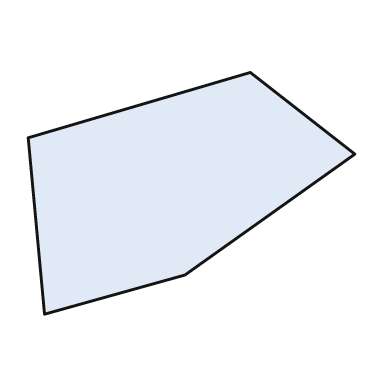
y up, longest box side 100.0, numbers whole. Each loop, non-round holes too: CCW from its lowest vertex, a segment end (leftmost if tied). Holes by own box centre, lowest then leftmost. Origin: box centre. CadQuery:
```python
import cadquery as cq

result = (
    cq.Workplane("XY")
    .moveTo(-45.0, -37.0)
    .lineTo(-2.0, -25.0)
    .lineTo(50.0, 12.0)
    .lineTo(18.0, 37.0)
    .lineTo(-50.0, 17.0)
    .close()
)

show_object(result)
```